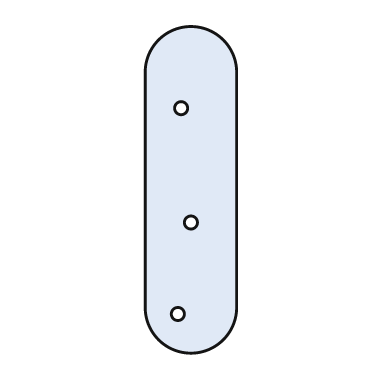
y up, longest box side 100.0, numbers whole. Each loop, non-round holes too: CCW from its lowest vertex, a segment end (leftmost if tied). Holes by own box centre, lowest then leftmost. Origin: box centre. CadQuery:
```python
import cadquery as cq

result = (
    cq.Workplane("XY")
    .moveTo(-14.0, -36.0)
    .threePointArc((0.0, -50.0), (14.0, -36.0))
    .lineTo(14.0, 36.0)
    .threePointArc((0.0, 50.0), (-14.0, 36.0))
    .close()
    .moveTo(-4.0, -38.0)
    .circle(2.0)
    .moveTo(0.0, -10.0)
    .circle(2.0)
    .moveTo(-3.0, 25.0)
    .circle(2.0)
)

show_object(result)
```